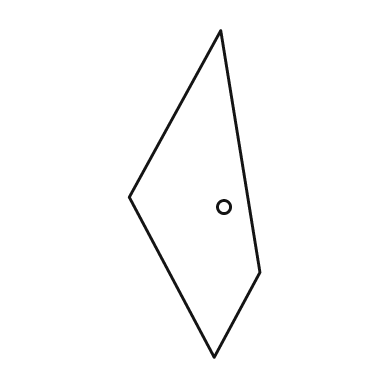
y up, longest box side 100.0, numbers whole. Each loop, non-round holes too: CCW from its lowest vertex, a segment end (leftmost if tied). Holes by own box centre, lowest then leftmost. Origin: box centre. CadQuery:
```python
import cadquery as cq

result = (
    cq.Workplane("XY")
    .moveTo(6.0, -50.0)
    .lineTo(20.0, -24.0)
    .lineTo(8.0, 50.0)
    .lineTo(-20.0, -1.0)
    .close()
    .moveTo(9.0, -4.0)
    .circle(2.0)
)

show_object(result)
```